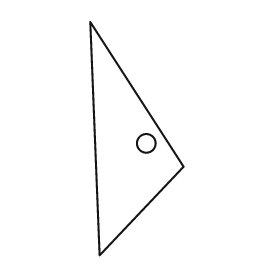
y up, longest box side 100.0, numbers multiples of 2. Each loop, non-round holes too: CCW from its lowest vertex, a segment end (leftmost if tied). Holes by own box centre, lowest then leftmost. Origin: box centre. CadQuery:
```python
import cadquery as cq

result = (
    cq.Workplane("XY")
    .moveTo(-16.0, -50.0)
    .lineTo(20.0, -12.0)
    .lineTo(-20.0, 50.0)
    .close()
    .moveTo(4.0, -2.0)
    .circle(4.0)
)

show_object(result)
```